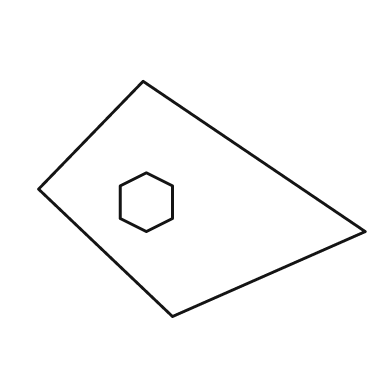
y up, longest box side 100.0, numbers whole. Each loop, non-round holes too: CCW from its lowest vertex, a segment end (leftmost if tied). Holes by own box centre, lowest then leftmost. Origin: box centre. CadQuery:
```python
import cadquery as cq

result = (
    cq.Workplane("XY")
    .moveTo(-9.0, -36.0)
    .lineTo(50.0, -10.0)
    .lineTo(-18.0, 36.0)
    .lineTo(-50.0, 3.0)
    .close()
    .moveTo(-17.0, -10.0)
    .lineTo(-9.0, -6.0)
    .lineTo(-9.0, 4.0)
    .lineTo(-17.0, 8.0)
    .lineTo(-25.0, 4.0)
    .lineTo(-25.0, -6.0)
    .close()
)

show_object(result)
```